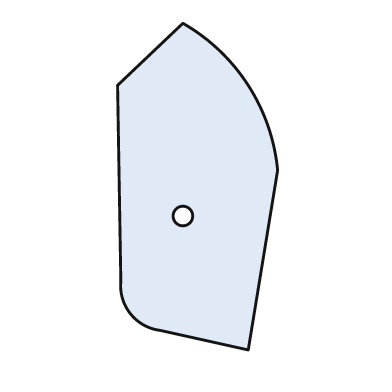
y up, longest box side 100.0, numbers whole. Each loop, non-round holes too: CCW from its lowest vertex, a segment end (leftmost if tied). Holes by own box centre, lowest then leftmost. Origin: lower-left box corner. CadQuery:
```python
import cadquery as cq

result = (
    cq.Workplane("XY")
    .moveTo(40.0, 0.0)
    .lineTo(49.0, 55.0)
    .threePointArc((40.0, 81.0), (20.0, 100.0))
    .lineTo(0.0, 81.0)
    .lineTo(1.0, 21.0)
    .threePointArc((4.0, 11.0), (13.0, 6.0))
    .close()
    .moveTo(20.0, 41.0)
    .circle(3.0)
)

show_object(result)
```